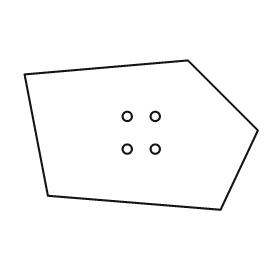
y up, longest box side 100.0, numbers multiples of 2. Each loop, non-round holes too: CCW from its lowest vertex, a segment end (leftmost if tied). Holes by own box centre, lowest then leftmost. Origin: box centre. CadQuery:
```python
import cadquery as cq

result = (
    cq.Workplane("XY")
    .moveTo(34.0, -32.0)
    .lineTo(50.0, 2.0)
    .lineTo(20.0, 32.0)
    .lineTo(-50.0, 26.0)
    .lineTo(-40.0, -26.0)
    .close()
    .moveTo(-6.0, -6.0)
    .circle(2.0)
    .moveTo(6.0, -6.0)
    .circle(2.0)
    .moveTo(-6.0, 8.0)
    .circle(2.0)
    .moveTo(6.0, 8.0)
    .circle(2.0)
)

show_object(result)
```